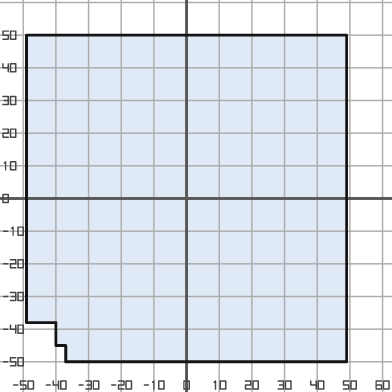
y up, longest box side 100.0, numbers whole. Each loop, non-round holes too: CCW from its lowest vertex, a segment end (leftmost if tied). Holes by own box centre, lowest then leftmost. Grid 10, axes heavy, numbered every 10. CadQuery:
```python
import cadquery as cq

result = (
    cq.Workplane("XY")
    .moveTo(-37.0, -50.0)
    .lineTo(49.0, -50.0)
    .lineTo(49.0, 50.0)
    .lineTo(-49.0, 50.0)
    .lineTo(-49.0, -38.0)
    .lineTo(-40.0, -38.0)
    .lineTo(-40.0, -45.0)
    .lineTo(-37.0, -45.0)
    .close()
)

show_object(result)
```